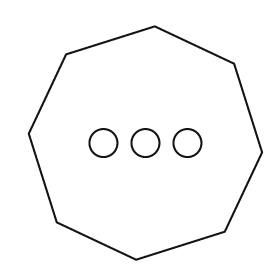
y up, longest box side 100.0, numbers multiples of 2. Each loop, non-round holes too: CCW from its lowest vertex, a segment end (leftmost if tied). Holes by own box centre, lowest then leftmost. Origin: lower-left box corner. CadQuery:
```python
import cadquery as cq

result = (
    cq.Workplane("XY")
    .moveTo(46.0, 0.0)
    .lineTo(84.0, 12.0)
    .lineTo(100.0, 46.0)
    .lineTo(88.0, 84.0)
    .lineTo(54.0, 100.0)
    .lineTo(16.0, 88.0)
    .lineTo(0.0, 54.0)
    .lineTo(12.0, 16.0)
    .close()
    .moveTo(32.0, 50.0)
    .circle(6.0)
    .moveTo(50.0, 50.0)
    .circle(6.0)
    .moveTo(68.0, 50.0)
    .circle(6.0)
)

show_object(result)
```